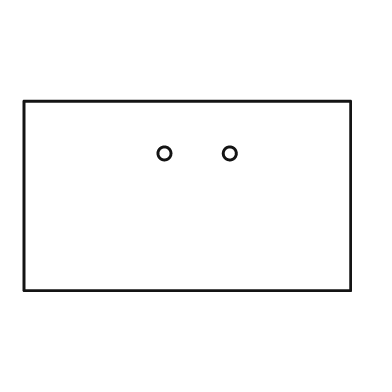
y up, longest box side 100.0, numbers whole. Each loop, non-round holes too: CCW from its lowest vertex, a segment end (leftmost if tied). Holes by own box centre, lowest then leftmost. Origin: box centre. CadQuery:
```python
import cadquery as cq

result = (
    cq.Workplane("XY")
    .moveTo(-50.0, -29.0)
    .lineTo(50.0, -29.0)
    .lineTo(50.0, 29.0)
    .lineTo(-50.0, 29.0)
    .close()
    .moveTo(-7.0, 13.0)
    .circle(2.0)
    .moveTo(13.0, 13.0)
    .circle(2.0)
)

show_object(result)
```